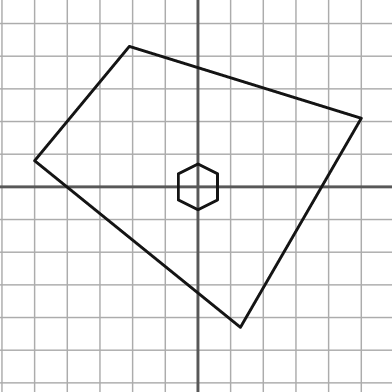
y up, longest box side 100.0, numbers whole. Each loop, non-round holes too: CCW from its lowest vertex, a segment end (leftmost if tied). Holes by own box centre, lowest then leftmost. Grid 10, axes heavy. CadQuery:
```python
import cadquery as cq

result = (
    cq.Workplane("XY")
    .moveTo(13.0, -43.0)
    .lineTo(50.0, 21.0)
    .lineTo(-21.0, 43.0)
    .lineTo(-50.0, 8.0)
    .close()
    .moveTo(0.0, -7.0)
    .lineTo(6.0, -4.0)
    .lineTo(6.0, 4.0)
    .lineTo(0.0, 7.0)
    .lineTo(-6.0, 4.0)
    .lineTo(-6.0, -4.0)
    .close()
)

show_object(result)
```